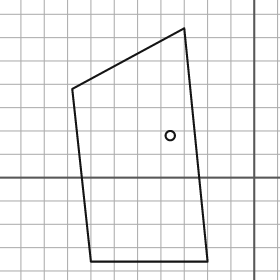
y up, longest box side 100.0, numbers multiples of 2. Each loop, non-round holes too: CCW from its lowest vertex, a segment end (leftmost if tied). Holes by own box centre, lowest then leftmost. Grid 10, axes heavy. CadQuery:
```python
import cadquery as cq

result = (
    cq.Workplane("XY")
    .moveTo(-70.0, -36.0)
    .lineTo(-20.0, -36.0)
    .lineTo(-30.0, 64.0)
    .lineTo(-78.0, 38.0)
    .close()
    .moveTo(-36.0, 18.0)
    .circle(2.0)
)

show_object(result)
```